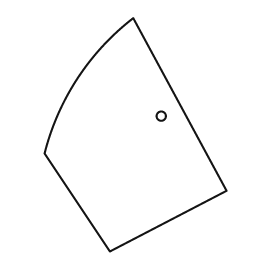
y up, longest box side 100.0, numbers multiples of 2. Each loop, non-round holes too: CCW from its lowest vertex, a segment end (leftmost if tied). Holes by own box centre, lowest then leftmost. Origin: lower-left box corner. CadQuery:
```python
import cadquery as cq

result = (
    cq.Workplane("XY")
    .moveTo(28.0, 0.0)
    .lineTo(78.0, 26.0)
    .lineTo(38.0, 100.0)
    .threePointArc((14.0, 74.0), (0.0, 42.0))
    .close()
    .moveTo(50.0, 58.0)
    .circle(2.0)
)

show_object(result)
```